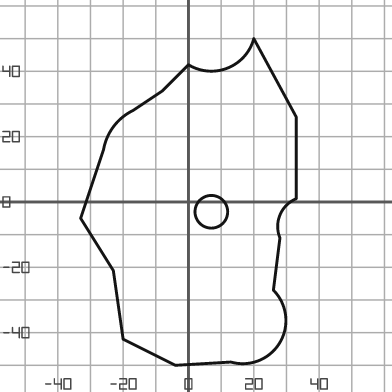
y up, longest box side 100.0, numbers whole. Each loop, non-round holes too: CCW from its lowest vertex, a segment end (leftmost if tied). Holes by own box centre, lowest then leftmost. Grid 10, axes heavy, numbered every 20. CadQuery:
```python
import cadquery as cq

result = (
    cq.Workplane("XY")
    .moveTo(-4.0, -50.0)
    .lineTo(13.0, -49.0)
    .threePointArc((28.0, -43.0), (26.0, -27.0))
    .lineTo(28.0, -11.0)
    .threePointArc((28.0, -4.0), (33.0, 1.0))
    .lineTo(33.0, 26.0)
    .lineTo(20.0, 50.0)
    .threePointArc((12.0, 41.0), (0.0, 42.0))
    .lineTo(-8.0, 34.0)
    .lineTo(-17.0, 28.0)
    .threePointArc((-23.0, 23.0), (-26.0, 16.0))
    .lineTo(-33.0, -5.0)
    .lineTo(-23.0, -21.0)
    .lineTo(-20.0, -42.0)
    .close()
    .moveTo(7.0, -3.0)
    .circle(5.0)
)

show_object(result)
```